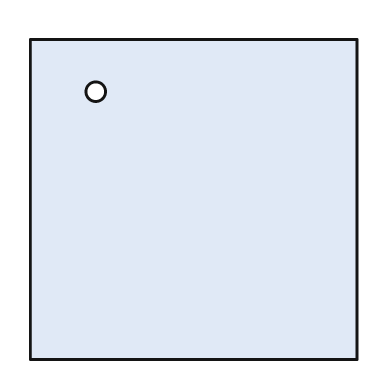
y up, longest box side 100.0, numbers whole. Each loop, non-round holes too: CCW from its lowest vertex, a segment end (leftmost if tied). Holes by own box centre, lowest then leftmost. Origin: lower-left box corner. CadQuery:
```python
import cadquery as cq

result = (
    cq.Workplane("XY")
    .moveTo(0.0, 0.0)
    .lineTo(100.0, 0.0)
    .lineTo(100.0, 98.0)
    .lineTo(0.0, 98.0)
    .close()
    .moveTo(20.0, 82.0)
    .circle(3.0)
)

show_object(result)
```